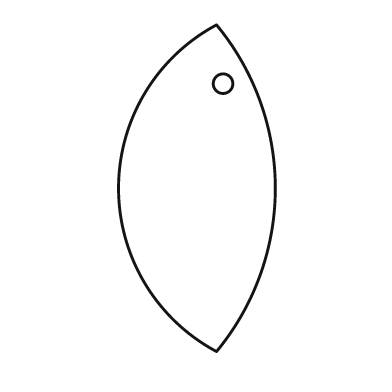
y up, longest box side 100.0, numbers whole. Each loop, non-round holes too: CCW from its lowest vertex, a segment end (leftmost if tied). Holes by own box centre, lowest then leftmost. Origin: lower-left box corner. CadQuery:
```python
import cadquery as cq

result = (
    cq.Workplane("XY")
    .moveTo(30.0, 0.0)
    .threePointArc((48.0, 50.0), (30.0, 100.0))
    .threePointArc((0.0, 50.0), (30.0, 0.0))
    .close()
    .moveTo(32.0, 82.0)
    .circle(3.0)
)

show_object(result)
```